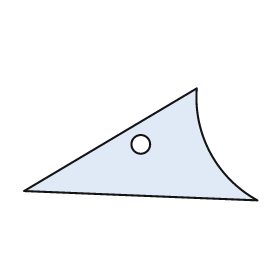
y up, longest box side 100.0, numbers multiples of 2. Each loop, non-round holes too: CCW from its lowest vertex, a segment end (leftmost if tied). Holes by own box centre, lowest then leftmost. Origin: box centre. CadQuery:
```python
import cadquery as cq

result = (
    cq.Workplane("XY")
    .moveTo(50.0, -24.0)
    .threePointArc((30.0, -4.0), (24.0, 24.0))
    .lineTo(-50.0, -20.0)
    .close()
    .moveTo(0.0, 0.0)
    .circle(4.0)
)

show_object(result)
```